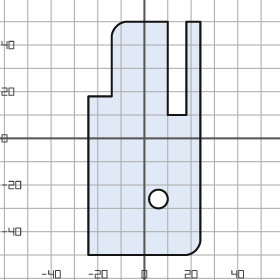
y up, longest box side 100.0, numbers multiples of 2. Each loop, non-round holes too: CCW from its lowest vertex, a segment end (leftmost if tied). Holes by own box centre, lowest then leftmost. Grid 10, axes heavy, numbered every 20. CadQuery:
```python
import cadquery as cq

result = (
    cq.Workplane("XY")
    .moveTo(-24.0, -50.0)
    .lineTo(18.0, -50.0)
    .threePointArc((22.0, -48.0), (24.0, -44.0))
    .lineTo(24.0, 50.0)
    .lineTo(18.0, 50.0)
    .lineTo(18.0, 10.0)
    .lineTo(10.0, 10.0)
    .lineTo(10.0, 50.0)
    .lineTo(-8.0, 50.0)
    .threePointArc((-12.0, 48.0), (-14.0, 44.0))
    .lineTo(-14.0, 18.0)
    .lineTo(-24.0, 18.0)
    .close()
    .moveTo(6.0, -26.0)
    .circle(4.0)
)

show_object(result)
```